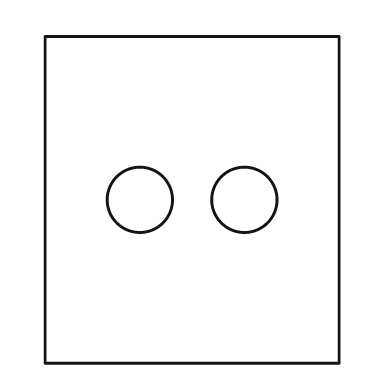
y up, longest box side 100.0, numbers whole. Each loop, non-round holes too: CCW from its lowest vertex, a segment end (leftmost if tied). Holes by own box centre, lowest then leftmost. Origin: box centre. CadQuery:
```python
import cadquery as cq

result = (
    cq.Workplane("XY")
    .moveTo(-45.0, -50.0)
    .lineTo(45.0, -50.0)
    .lineTo(45.0, 50.0)
    .lineTo(-45.0, 50.0)
    .close()
    .moveTo(-16.0, 0.0)
    .circle(10.0)
    .moveTo(16.0, 0.0)
    .circle(10.0)
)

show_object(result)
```